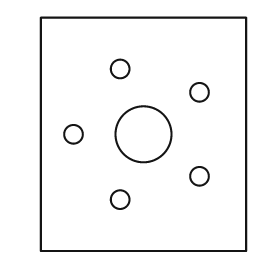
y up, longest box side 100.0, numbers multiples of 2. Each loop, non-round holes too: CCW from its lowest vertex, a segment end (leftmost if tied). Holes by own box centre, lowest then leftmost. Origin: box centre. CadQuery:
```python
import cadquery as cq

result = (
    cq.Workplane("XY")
    .moveTo(-44.0, -50.0)
    .lineTo(44.0, -50.0)
    .lineTo(44.0, 50.0)
    .lineTo(-44.0, 50.0)
    .close()
    .moveTo(-10.0, -28.0)
    .circle(4.0)
    .moveTo(24.0, -18.0)
    .circle(4.0)
    .moveTo(-30.0, 0.0)
    .circle(4.0)
    .moveTo(0.0, 0.0)
    .circle(12.0)
    .moveTo(24.0, 18.0)
    .circle(4.0)
    .moveTo(-10.0, 28.0)
    .circle(4.0)
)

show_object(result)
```